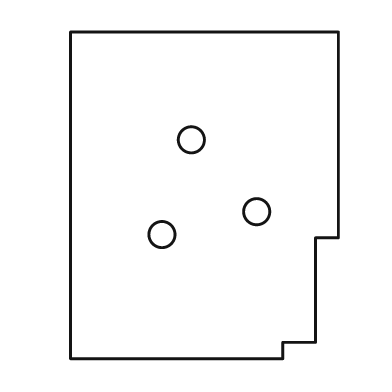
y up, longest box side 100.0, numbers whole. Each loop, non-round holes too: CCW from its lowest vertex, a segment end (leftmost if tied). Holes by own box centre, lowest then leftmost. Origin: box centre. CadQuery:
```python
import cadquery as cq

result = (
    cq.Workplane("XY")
    .moveTo(-41.0, -50.0)
    .lineTo(24.0, -50.0)
    .lineTo(24.0, -45.0)
    .lineTo(34.0, -45.0)
    .lineTo(34.0, -13.0)
    .lineTo(41.0, -13.0)
    .lineTo(41.0, 50.0)
    .lineTo(-41.0, 50.0)
    .close()
    .moveTo(-13.0, -12.0)
    .circle(4.0)
    .moveTo(16.0, -5.0)
    .circle(4.0)
    .moveTo(-4.0, 17.0)
    .circle(4.0)
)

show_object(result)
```